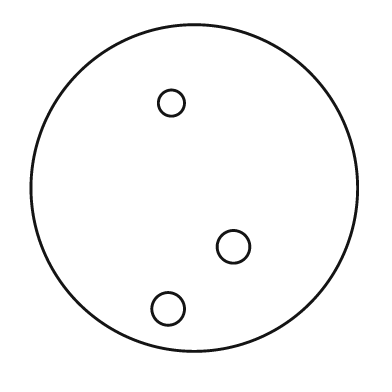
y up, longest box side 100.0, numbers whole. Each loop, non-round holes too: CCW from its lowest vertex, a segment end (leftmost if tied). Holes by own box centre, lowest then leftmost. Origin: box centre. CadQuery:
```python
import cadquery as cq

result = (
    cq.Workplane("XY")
    .moveTo(0.0, 0.0)
    .circle(50.0)
    .moveTo(-8.0, -37.0)
    .circle(5.0)
    .moveTo(12.0, -18.0)
    .circle(5.0)
    .moveTo(-7.0, 26.0)
    .circle(4.0)
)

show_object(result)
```